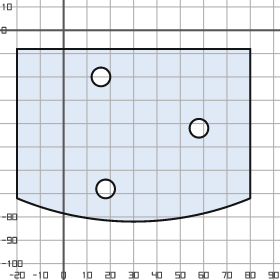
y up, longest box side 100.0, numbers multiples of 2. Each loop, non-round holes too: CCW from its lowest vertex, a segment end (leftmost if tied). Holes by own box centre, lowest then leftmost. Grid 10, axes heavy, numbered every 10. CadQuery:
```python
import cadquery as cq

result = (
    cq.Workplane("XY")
    .moveTo(-20.0, -72.0)
    .threePointArc((30.0, -82.0), (80.0, -72.0))
    .lineTo(80.0, -8.0)
    .lineTo(-20.0, -8.0)
    .close()
    .moveTo(18.0, -68.0)
    .circle(4.0)
    .moveTo(58.0, -42.0)
    .circle(4.0)
    .moveTo(16.0, -20.0)
    .circle(4.0)
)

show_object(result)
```